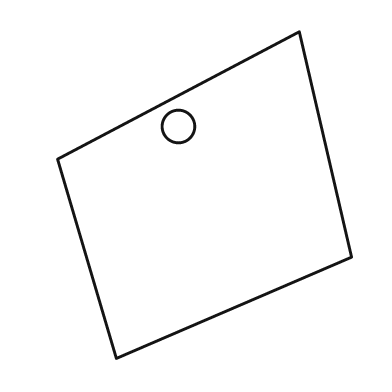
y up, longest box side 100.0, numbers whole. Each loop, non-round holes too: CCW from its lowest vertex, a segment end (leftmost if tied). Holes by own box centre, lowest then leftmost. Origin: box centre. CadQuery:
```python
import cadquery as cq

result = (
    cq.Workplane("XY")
    .moveTo(-27.0, -50.0)
    .lineTo(45.0, -19.0)
    .lineTo(29.0, 50.0)
    .lineTo(-45.0, 11.0)
    .close()
    .moveTo(-8.0, 21.0)
    .circle(5.0)
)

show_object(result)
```